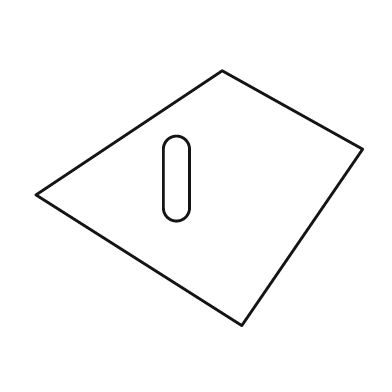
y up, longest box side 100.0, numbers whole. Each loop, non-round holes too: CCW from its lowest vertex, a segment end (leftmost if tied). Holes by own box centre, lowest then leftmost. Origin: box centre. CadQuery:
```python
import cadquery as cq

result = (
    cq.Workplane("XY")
    .moveTo(13.0, -39.0)
    .lineTo(50.0, 15.0)
    .lineTo(7.0, 39.0)
    .lineTo(-50.0, 1.0)
    .close()
    .moveTo(-11.0, -3.0)
    .threePointArc((-7.0, -7.0), (-3.0, -3.0))
    .lineTo(-3.0, 15.0)
    .threePointArc((-7.0, 19.0), (-11.0, 15.0))
    .close()
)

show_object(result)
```